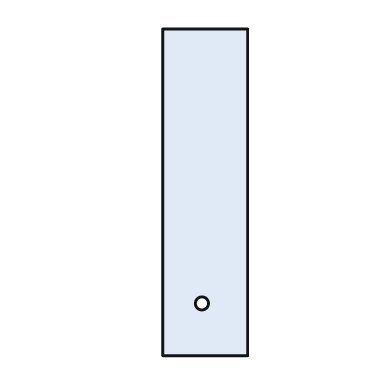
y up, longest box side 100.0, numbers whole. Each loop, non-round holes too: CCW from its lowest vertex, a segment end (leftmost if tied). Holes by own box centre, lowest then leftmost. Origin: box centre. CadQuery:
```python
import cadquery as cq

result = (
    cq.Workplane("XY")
    .moveTo(-13.0, -50.0)
    .lineTo(13.0, -50.0)
    .lineTo(13.0, 50.0)
    .lineTo(-13.0, 50.0)
    .close()
    .moveTo(-1.0, -34.0)
    .circle(2.0)
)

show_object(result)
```